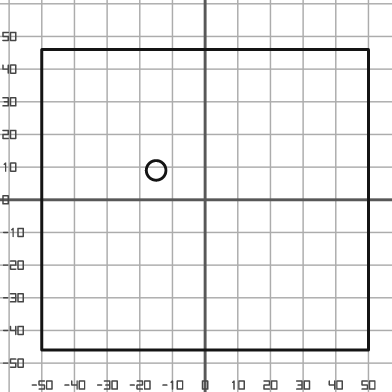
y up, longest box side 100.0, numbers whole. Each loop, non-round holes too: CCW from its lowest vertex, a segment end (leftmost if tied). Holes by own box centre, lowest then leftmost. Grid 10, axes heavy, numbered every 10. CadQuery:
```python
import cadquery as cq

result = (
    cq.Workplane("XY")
    .moveTo(-50.0, -46.0)
    .lineTo(50.0, -46.0)
    .lineTo(50.0, 46.0)
    .lineTo(-50.0, 46.0)
    .close()
    .moveTo(-15.0, 9.0)
    .circle(3.0)
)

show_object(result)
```